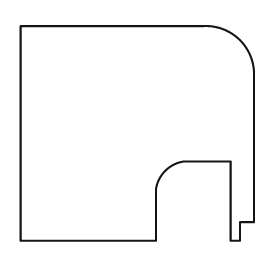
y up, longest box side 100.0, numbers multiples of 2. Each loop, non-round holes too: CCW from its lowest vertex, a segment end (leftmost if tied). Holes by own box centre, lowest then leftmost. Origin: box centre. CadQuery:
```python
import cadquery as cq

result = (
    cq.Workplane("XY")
    .moveTo(-50.0, -46.0)
    .lineTo(8.0, -46.0)
    .lineTo(8.0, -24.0)
    .threePointArc((12.0, -16.0), (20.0, -12.0))
    .lineTo(40.0, -12.0)
    .lineTo(40.0, -46.0)
    .lineTo(44.0, -46.0)
    .lineTo(44.0, -38.0)
    .lineTo(50.0, -38.0)
    .lineTo(50.0, 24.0)
    .threePointArc((44.0, 40.0), (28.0, 46.0))
    .lineTo(-50.0, 46.0)
    .close()
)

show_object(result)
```